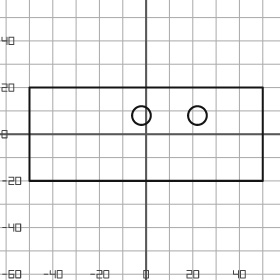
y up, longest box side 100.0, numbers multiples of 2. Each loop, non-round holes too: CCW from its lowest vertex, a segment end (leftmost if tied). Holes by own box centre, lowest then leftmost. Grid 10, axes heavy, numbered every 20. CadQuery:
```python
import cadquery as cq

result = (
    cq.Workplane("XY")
    .moveTo(-50.0, -20.0)
    .lineTo(50.0, -20.0)
    .lineTo(50.0, 20.0)
    .lineTo(-50.0, 20.0)
    .close()
    .moveTo(-2.0, 8.0)
    .circle(4.0)
    .moveTo(22.0, 8.0)
    .circle(4.0)
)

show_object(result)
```